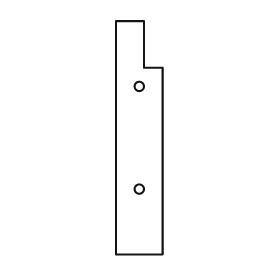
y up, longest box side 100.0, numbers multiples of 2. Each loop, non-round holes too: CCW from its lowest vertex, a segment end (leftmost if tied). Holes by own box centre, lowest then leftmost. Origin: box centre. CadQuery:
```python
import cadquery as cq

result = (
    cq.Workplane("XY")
    .moveTo(-10.0, -50.0)
    .lineTo(10.0, -50.0)
    .lineTo(10.0, 30.0)
    .lineTo(2.0, 30.0)
    .lineTo(2.0, 50.0)
    .lineTo(-10.0, 50.0)
    .close()
    .moveTo(0.0, -22.0)
    .circle(2.0)
    .moveTo(0.0, 22.0)
    .circle(2.0)
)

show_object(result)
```